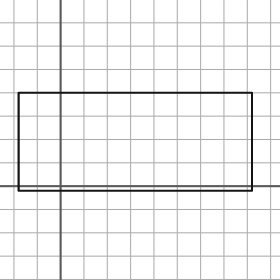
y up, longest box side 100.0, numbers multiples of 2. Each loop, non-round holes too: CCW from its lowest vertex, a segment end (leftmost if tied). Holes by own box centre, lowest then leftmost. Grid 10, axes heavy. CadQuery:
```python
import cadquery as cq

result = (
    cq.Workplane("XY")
    .moveTo(-18.0, -2.0)
    .lineTo(82.0, -2.0)
    .lineTo(82.0, 40.0)
    .lineTo(-18.0, 40.0)
    .close()
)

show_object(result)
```